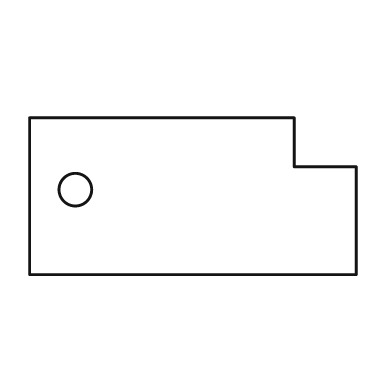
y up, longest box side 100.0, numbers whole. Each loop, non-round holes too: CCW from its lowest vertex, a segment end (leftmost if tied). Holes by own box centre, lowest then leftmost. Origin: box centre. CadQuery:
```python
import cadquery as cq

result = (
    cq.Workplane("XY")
    .moveTo(-50.0, -24.0)
    .lineTo(50.0, -24.0)
    .lineTo(50.0, 9.0)
    .lineTo(31.0, 9.0)
    .lineTo(31.0, 24.0)
    .lineTo(-50.0, 24.0)
    .close()
    .moveTo(-36.0, 2.0)
    .circle(5.0)
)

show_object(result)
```